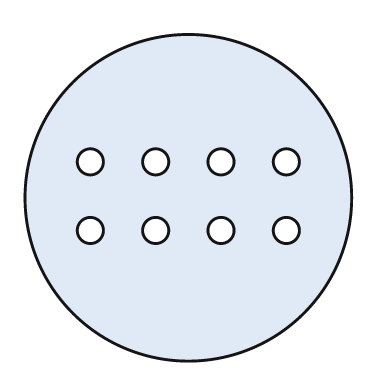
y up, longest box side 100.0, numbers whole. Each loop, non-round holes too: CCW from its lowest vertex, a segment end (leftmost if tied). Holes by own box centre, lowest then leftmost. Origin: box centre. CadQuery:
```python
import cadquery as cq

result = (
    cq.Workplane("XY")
    .moveTo(0.0, 0.0)
    .circle(50.0)
    .moveTo(-30.0, -10.0)
    .circle(4.0)
    .moveTo(-10.0, -10.0)
    .circle(4.0)
    .moveTo(10.0, -10.0)
    .circle(4.0)
    .moveTo(30.0, -10.0)
    .circle(4.0)
    .moveTo(-30.0, 11.0)
    .circle(4.0)
    .moveTo(-10.0, 11.0)
    .circle(4.0)
    .moveTo(10.0, 11.0)
    .circle(4.0)
    .moveTo(30.0, 11.0)
    .circle(4.0)
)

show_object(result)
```